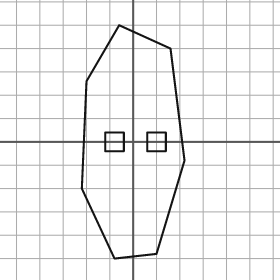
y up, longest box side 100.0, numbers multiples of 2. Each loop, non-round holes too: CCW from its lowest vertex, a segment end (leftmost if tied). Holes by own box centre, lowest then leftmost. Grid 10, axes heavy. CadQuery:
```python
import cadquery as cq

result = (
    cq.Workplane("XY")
    .moveTo(-8.0, -50.0)
    .lineTo(10.0, -48.0)
    .lineTo(22.0, -8.0)
    .lineTo(16.0, 40.0)
    .lineTo(-6.0, 50.0)
    .lineTo(-20.0, 26.0)
    .lineTo(-22.0, -20.0)
    .close()
    .moveTo(-12.0, -4.0)
    .lineTo(-4.0, -4.0)
    .lineTo(-4.0, 4.0)
    .lineTo(-12.0, 4.0)
    .close()
    .moveTo(6.0, -4.0)
    .lineTo(14.0, -4.0)
    .lineTo(14.0, 4.0)
    .lineTo(6.0, 4.0)
    .close()
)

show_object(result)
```